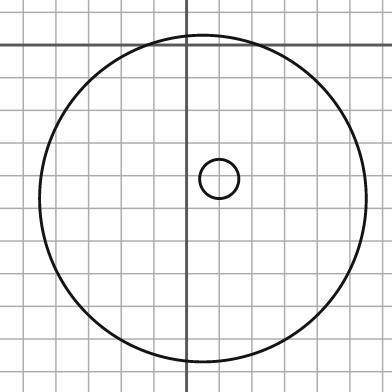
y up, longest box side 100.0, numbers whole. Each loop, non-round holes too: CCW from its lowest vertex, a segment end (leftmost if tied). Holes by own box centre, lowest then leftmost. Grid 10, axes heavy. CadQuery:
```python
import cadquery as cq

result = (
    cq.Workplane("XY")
    .moveTo(5.0, -47.0)
    .circle(50.0)
    .moveTo(10.0, -41.0)
    .circle(6.0)
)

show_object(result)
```